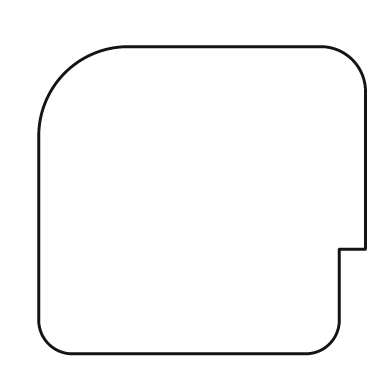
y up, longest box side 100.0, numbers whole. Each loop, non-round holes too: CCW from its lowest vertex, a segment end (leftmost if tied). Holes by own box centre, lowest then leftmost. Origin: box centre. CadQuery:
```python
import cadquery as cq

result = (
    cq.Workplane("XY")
    .moveTo(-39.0, -47.0)
    .lineTo(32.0, -47.0)
    .threePointArc((39.0, -44.0), (42.0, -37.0))
    .lineTo(42.0, -15.0)
    .lineTo(50.0, -15.0)
    .lineTo(50.0, 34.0)
    .threePointArc((46.0, 43.0), (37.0, 47.0))
    .lineTo(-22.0, 47.0)
    .threePointArc((-42.0, 39.0), (-50.0, 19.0))
    .lineTo(-50.0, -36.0)
    .threePointArc((-47.0, -44.0), (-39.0, -47.0))
    .close()
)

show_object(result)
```